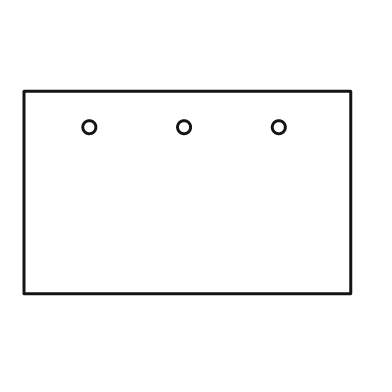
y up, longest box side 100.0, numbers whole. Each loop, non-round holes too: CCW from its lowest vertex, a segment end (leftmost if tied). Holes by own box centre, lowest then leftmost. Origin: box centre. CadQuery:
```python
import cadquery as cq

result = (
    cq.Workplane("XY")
    .moveTo(-50.0, -31.0)
    .lineTo(50.0, -31.0)
    .lineTo(50.0, 31.0)
    .lineTo(-50.0, 31.0)
    .close()
    .moveTo(-30.0, 20.0)
    .circle(2.0)
    .moveTo(-1.0, 20.0)
    .circle(2.0)
    .moveTo(28.0, 20.0)
    .circle(2.0)
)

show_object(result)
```